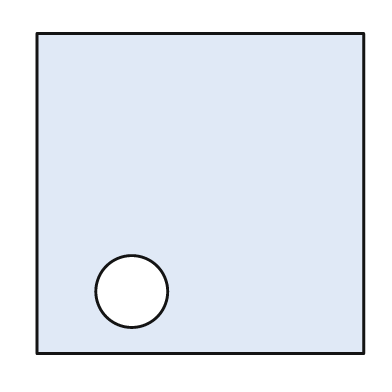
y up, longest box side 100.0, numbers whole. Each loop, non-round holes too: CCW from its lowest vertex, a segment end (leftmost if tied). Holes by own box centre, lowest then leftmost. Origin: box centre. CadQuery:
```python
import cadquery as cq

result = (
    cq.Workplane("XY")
    .moveTo(-50.0, -49.0)
    .lineTo(50.0, -49.0)
    .lineTo(50.0, 49.0)
    .lineTo(-50.0, 49.0)
    .close()
    .moveTo(-21.0, -30.0)
    .circle(11.0)
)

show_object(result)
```